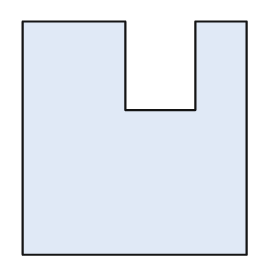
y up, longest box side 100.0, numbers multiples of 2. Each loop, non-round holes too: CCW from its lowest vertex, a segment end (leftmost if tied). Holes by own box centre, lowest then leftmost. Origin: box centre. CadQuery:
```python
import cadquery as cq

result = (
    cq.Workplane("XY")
    .moveTo(-48.0, -50.0)
    .lineTo(48.0, -50.0)
    .lineTo(48.0, 50.0)
    .lineTo(26.0, 50.0)
    .lineTo(26.0, 12.0)
    .lineTo(-4.0, 12.0)
    .lineTo(-4.0, 50.0)
    .lineTo(-48.0, 50.0)
    .close()
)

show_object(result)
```